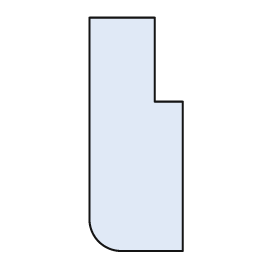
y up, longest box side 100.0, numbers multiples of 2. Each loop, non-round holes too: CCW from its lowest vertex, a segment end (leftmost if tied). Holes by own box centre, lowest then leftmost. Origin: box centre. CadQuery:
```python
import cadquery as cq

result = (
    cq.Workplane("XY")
    .moveTo(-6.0, -50.0)
    .lineTo(20.0, -50.0)
    .lineTo(20.0, 14.0)
    .lineTo(8.0, 14.0)
    .lineTo(8.0, 50.0)
    .lineTo(-20.0, 50.0)
    .lineTo(-20.0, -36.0)
    .threePointArc((-16.0, -46.0), (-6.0, -50.0))
    .close()
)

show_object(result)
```